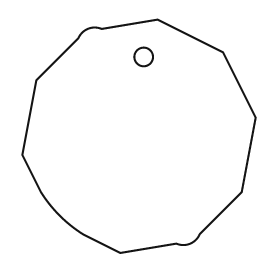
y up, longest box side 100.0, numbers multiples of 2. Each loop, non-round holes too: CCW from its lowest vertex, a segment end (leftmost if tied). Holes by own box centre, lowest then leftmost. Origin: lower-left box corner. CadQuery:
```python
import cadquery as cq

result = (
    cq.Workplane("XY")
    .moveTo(42.0, 0.0)
    .lineTo(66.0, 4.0)
    .threePointArc((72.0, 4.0), (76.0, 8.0))
    .lineTo(94.0, 26.0)
    .lineTo(100.0, 58.0)
    .lineTo(86.0, 86.0)
    .lineTo(58.0, 100.0)
    .lineTo(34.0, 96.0)
    .threePointArc((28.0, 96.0), (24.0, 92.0))
    .lineTo(6.0, 74.0)
    .lineTo(0.0, 42.0)
    .lineTo(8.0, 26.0)
    .threePointArc((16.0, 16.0), (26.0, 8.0))
    .close()
    .moveTo(52.0, 84.0)
    .circle(4.0)
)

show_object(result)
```